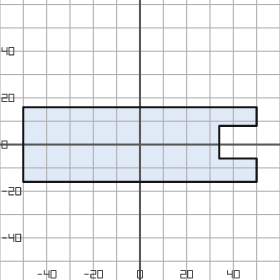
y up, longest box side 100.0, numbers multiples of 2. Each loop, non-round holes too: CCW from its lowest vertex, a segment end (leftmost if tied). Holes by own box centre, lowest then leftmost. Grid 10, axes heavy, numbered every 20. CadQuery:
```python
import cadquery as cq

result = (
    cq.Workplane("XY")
    .moveTo(-50.0, -16.0)
    .lineTo(50.0, -16.0)
    .lineTo(50.0, -6.0)
    .lineTo(34.0, -6.0)
    .lineTo(34.0, 8.0)
    .lineTo(50.0, 8.0)
    .lineTo(50.0, 16.0)
    .lineTo(-50.0, 16.0)
    .close()
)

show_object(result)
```